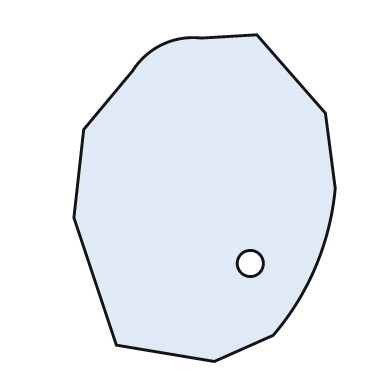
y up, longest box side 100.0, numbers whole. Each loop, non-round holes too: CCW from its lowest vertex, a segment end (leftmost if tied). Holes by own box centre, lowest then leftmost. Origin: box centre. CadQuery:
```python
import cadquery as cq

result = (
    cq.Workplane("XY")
    .moveTo(3.0, -50.0)
    .lineTo(21.0, -42.0)
    .threePointArc((34.0, -21.0), (40.0, 3.0))
    .lineTo(37.0, 26.0)
    .lineTo(16.0, 50.0)
    .lineTo(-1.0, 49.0)
    .threePointArc((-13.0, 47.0), (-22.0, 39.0))
    .lineTo(-37.0, 21.0)
    .lineTo(-40.0, -6.0)
    .lineTo(-27.0, -45.0)
    .close()
    .moveTo(14.0, -20.0)
    .circle(4.0)
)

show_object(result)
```